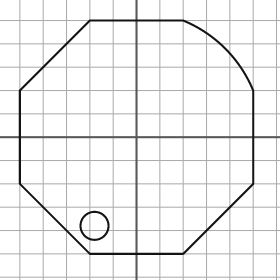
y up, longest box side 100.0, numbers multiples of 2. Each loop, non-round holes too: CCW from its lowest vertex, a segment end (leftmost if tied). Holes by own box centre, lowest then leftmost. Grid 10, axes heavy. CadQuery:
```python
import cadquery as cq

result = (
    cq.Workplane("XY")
    .moveTo(-20.0, -50.0)
    .lineTo(20.0, -50.0)
    .lineTo(50.0, -20.0)
    .lineTo(50.0, 20.0)
    .threePointArc((38.0, 38.0), (20.0, 50.0))
    .lineTo(-20.0, 50.0)
    .lineTo(-50.0, 20.0)
    .lineTo(-50.0, -20.0)
    .close()
    .moveTo(-18.0, -38.0)
    .circle(6.0)
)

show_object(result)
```